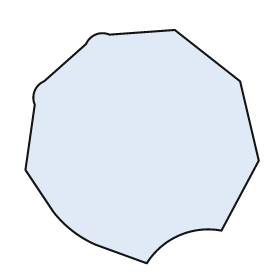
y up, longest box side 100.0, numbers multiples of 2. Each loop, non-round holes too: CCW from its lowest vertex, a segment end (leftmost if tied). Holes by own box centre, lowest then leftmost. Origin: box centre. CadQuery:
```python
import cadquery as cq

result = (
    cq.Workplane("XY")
    .moveTo(2.0, -50.0)
    .threePointArc((16.0, -38.0), (34.0, -36.0))
    .lineTo(50.0, -6.0)
    .lineTo(42.0, 28.0)
    .lineTo(14.0, 50.0)
    .lineTo(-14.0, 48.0)
    .threePointArc((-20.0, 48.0), (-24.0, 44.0))
    .lineTo(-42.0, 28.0)
    .threePointArc((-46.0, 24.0), (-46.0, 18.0))
    .lineTo(-50.0, -10.0)
    .lineTo(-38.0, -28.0)
    .threePointArc((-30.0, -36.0), (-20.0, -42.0))
    .close()
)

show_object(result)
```